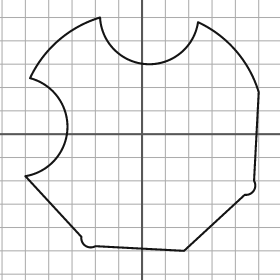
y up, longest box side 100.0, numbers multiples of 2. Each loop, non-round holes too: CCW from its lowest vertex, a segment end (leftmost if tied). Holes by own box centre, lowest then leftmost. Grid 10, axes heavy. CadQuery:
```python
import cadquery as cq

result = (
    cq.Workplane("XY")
    .moveTo(18.0, -50.0)
    .lineTo(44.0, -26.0)
    .threePointArc((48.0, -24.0), (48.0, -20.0))
    .lineTo(50.0, 18.0)
    .threePointArc((40.0, 36.0), (24.0, 48.0))
    .threePointArc((2.0, 30.0), (-18.0, 50.0))
    .threePointArc((-36.0, 40.0), (-48.0, 24.0))
    .threePointArc((-32.0, 2.0), (-50.0, -18.0))
    .lineTo(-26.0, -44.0)
    .threePointArc((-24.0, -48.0), (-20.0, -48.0))
    .close()
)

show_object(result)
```